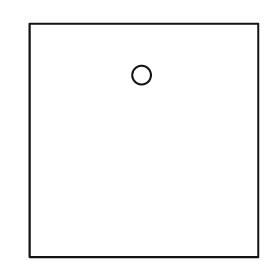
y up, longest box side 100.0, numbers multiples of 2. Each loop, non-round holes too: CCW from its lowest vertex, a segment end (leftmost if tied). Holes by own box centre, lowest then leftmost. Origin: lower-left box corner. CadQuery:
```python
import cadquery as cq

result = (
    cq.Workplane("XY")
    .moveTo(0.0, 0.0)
    .lineTo(98.0, 0.0)
    .lineTo(98.0, 100.0)
    .lineTo(0.0, 100.0)
    .close()
    .moveTo(48.0, 78.0)
    .circle(4.0)
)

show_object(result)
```